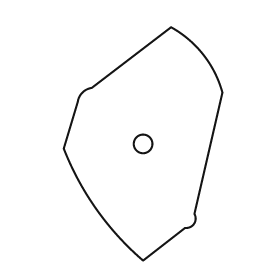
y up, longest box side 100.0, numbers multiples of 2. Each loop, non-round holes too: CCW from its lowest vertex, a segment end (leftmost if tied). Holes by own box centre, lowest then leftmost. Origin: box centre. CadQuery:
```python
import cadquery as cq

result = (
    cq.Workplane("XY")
    .moveTo(0.0, -50.0)
    .lineTo(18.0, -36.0)
    .threePointArc((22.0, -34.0), (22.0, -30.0))
    .lineTo(34.0, 22.0)
    .threePointArc((26.0, 38.0), (12.0, 50.0))
    .lineTo(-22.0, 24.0)
    .threePointArc((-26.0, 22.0), (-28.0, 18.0))
    .lineTo(-34.0, -2.0)
    .threePointArc((-20.0, -28.0), (0.0, -50.0))
    .close()
    .moveTo(0.0, 0.0)
    .circle(4.0)
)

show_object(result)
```